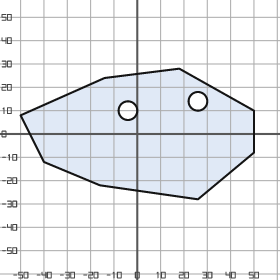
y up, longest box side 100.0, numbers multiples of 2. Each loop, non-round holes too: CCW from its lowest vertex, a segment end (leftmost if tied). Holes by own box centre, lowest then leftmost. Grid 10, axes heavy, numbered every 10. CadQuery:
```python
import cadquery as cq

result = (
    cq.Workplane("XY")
    .moveTo(26.0, -28.0)
    .lineTo(50.0, -8.0)
    .lineTo(50.0, 10.0)
    .lineTo(18.0, 28.0)
    .lineTo(-14.0, 24.0)
    .lineTo(-50.0, 8.0)
    .lineTo(-40.0, -12.0)
    .lineTo(-16.0, -22.0)
    .close()
    .moveTo(-4.0, 10.0)
    .circle(4.0)
    .moveTo(26.0, 14.0)
    .circle(4.0)
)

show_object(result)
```